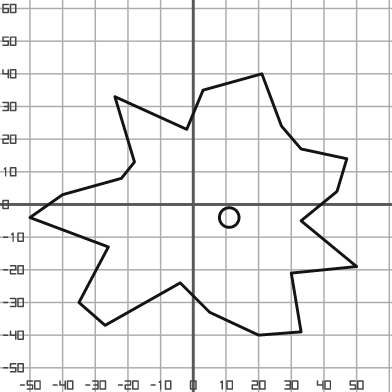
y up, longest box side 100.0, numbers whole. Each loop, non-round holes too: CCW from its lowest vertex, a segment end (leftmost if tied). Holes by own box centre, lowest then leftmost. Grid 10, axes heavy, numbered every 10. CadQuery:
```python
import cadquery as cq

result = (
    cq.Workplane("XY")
    .moveTo(20.0, -40.0)
    .lineTo(33.0, -39.0)
    .lineTo(30.0, -21.0)
    .lineTo(50.0, -19.0)
    .lineTo(33.0, -5.0)
    .lineTo(44.0, 4.0)
    .lineTo(47.0, 14.0)
    .lineTo(33.0, 17.0)
    .lineTo(27.0, 24.0)
    .lineTo(21.0, 40.0)
    .lineTo(3.0, 35.0)
    .lineTo(-2.0, 23.0)
    .lineTo(-24.0, 33.0)
    .lineTo(-18.0, 13.0)
    .lineTo(-22.0, 8.0)
    .lineTo(-40.0, 3.0)
    .lineTo(-50.0, -4.0)
    .lineTo(-26.0, -13.0)
    .lineTo(-35.0, -30.0)
    .lineTo(-27.0, -37.0)
    .lineTo(-4.0, -24.0)
    .lineTo(5.0, -33.0)
    .close()
    .moveTo(11.0, -4.0)
    .circle(3.0)
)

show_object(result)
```